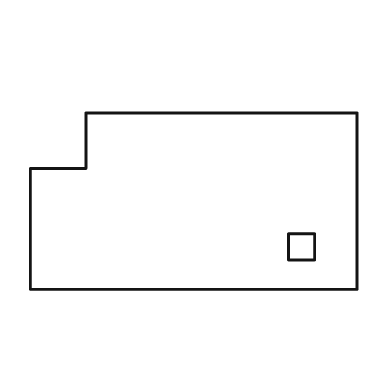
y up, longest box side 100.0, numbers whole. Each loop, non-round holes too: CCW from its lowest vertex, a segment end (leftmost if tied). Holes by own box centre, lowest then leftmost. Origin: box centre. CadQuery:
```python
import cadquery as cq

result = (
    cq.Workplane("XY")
    .moveTo(-50.0, -27.0)
    .lineTo(50.0, -27.0)
    .lineTo(50.0, 27.0)
    .lineTo(-33.0, 27.0)
    .lineTo(-33.0, 10.0)
    .lineTo(-50.0, 10.0)
    .close()
    .moveTo(29.0, -18.0)
    .lineTo(37.0, -18.0)
    .lineTo(37.0, -10.0)
    .lineTo(29.0, -10.0)
    .close()
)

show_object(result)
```